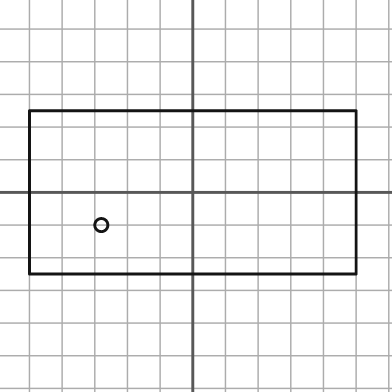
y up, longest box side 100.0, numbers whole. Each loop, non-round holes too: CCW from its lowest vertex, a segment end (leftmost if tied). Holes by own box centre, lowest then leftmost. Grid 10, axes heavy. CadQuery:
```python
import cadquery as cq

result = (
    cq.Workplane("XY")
    .moveTo(-50.0, -25.0)
    .lineTo(50.0, -25.0)
    .lineTo(50.0, 25.0)
    .lineTo(-50.0, 25.0)
    .close()
    .moveTo(-28.0, -10.0)
    .circle(2.0)
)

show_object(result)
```